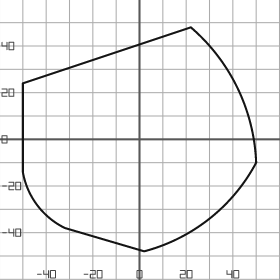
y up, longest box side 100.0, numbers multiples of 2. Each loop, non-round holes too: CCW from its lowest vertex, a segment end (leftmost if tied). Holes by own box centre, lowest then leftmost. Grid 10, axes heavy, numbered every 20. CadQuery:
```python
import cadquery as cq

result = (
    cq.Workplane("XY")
    .moveTo(2.0, -48.0)
    .threePointArc((30.0, -34.0), (50.0, -10.0))
    .threePointArc((42.0, 22.0), (22.0, 48.0))
    .lineTo(-50.0, 24.0)
    .lineTo(-50.0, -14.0)
    .threePointArc((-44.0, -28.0), (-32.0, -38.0))
    .close()
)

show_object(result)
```